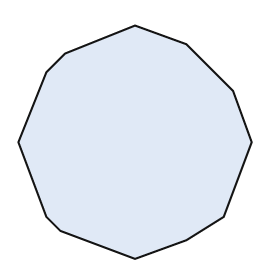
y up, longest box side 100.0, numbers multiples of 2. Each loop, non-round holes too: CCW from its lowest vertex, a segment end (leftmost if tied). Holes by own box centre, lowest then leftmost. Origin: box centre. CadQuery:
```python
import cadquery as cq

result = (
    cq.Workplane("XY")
    .moveTo(0.0, -50.0)
    .lineTo(22.0, -42.0)
    .lineTo(38.0, -32.0)
    .lineTo(50.0, 0.0)
    .lineTo(42.0, 22.0)
    .lineTo(22.0, 42.0)
    .lineTo(0.0, 50.0)
    .lineTo(-30.0, 38.0)
    .lineTo(-38.0, 30.0)
    .lineTo(-50.0, 0.0)
    .lineTo(-38.0, -32.0)
    .lineTo(-32.0, -38.0)
    .close()
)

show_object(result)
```